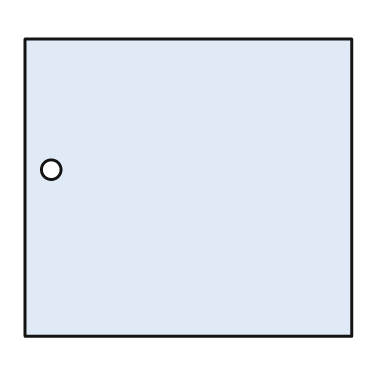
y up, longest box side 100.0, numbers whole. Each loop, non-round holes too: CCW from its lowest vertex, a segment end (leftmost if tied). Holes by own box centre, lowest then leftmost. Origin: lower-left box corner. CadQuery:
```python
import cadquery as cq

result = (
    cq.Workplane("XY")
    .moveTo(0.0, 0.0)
    .lineTo(100.0, 0.0)
    .lineTo(100.0, 91.0)
    .lineTo(0.0, 91.0)
    .close()
    .moveTo(8.0, 51.0)
    .circle(3.0)
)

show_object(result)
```